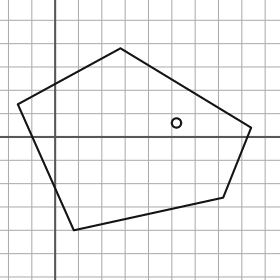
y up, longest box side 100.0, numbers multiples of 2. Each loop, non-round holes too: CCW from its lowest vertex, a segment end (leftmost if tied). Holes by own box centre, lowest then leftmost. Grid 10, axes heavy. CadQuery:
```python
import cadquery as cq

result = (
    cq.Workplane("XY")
    .moveTo(8.0, -40.0)
    .lineTo(72.0, -26.0)
    .lineTo(84.0, 4.0)
    .lineTo(28.0, 38.0)
    .lineTo(-16.0, 14.0)
    .close()
    .moveTo(52.0, 6.0)
    .circle(2.0)
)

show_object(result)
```